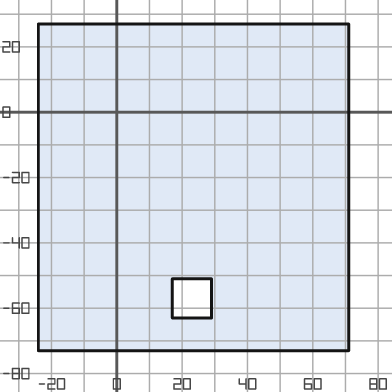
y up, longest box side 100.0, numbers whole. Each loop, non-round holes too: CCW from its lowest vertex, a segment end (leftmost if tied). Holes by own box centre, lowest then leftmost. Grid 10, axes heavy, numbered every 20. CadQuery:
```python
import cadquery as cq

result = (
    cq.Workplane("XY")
    .moveTo(-24.0, -73.0)
    .lineTo(71.0, -73.0)
    .lineTo(71.0, 27.0)
    .lineTo(-24.0, 27.0)
    .close()
    .moveTo(17.0, -63.0)
    .lineTo(29.0, -63.0)
    .lineTo(29.0, -51.0)
    .lineTo(17.0, -51.0)
    .close()
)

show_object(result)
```